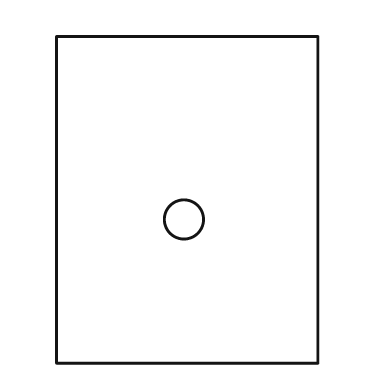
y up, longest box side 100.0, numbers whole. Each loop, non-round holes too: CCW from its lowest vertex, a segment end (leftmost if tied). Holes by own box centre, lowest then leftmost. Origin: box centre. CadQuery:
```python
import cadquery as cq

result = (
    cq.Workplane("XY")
    .moveTo(-40.0, -50.0)
    .lineTo(40.0, -50.0)
    .lineTo(40.0, 50.0)
    .lineTo(-40.0, 50.0)
    .close()
    .moveTo(-1.0, -6.0)
    .circle(6.0)
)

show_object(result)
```